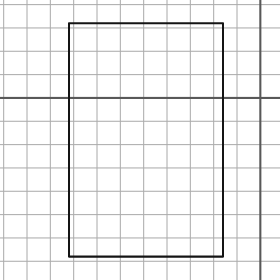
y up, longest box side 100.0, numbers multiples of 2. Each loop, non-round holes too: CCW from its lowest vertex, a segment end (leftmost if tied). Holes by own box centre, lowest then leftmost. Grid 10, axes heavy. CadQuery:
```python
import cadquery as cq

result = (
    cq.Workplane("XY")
    .moveTo(-82.0, -68.0)
    .lineTo(-16.0, -68.0)
    .lineTo(-16.0, 32.0)
    .lineTo(-82.0, 32.0)
    .close()
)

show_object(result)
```